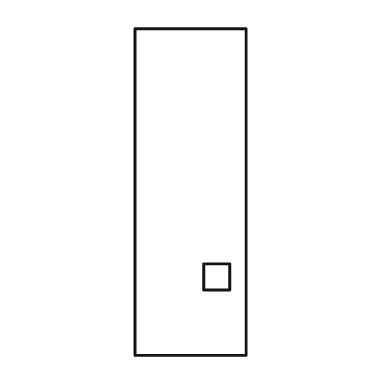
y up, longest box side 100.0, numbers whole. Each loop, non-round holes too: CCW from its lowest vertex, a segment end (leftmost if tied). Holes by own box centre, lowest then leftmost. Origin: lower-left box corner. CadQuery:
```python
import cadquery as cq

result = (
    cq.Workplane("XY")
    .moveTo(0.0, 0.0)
    .lineTo(34.0, 0.0)
    .lineTo(34.0, 100.0)
    .lineTo(0.0, 100.0)
    .close()
    .moveTo(21.0, 20.0)
    .lineTo(29.0, 20.0)
    .lineTo(29.0, 28.0)
    .lineTo(21.0, 28.0)
    .close()
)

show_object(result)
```